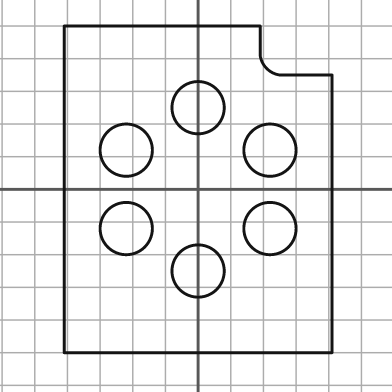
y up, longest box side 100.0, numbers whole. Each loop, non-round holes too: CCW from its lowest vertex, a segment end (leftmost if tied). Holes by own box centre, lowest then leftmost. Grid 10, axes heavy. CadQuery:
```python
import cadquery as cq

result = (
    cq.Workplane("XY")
    .moveTo(-41.0, -50.0)
    .lineTo(41.0, -50.0)
    .lineTo(41.0, 35.0)
    .lineTo(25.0, 35.0)
    .threePointArc((21.0, 37.0), (19.0, 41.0))
    .lineTo(19.0, 50.0)
    .lineTo(-41.0, 50.0)
    .close()
    .moveTo(0.0, -25.0)
    .circle(8.0)
    .moveTo(-22.0, -12.0)
    .circle(8.0)
    .moveTo(22.0, -12.0)
    .circle(8.0)
    .moveTo(-22.0, 12.0)
    .circle(8.0)
    .moveTo(22.0, 12.0)
    .circle(8.0)
    .moveTo(0.0, 25.0)
    .circle(8.0)
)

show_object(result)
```